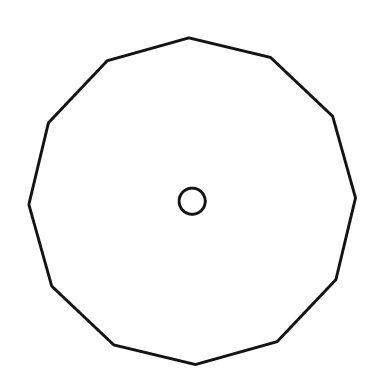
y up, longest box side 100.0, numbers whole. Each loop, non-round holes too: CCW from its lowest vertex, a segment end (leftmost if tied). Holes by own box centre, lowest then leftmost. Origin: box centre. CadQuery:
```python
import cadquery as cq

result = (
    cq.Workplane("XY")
    .moveTo(1.0, -50.0)
    .lineTo(26.0, -43.0)
    .lineTo(44.0, -24.0)
    .lineTo(50.0, 1.0)
    .lineTo(43.0, 26.0)
    .lineTo(24.0, 44.0)
    .lineTo(-1.0, 50.0)
    .lineTo(-26.0, 43.0)
    .lineTo(-44.0, 24.0)
    .lineTo(-50.0, -1.0)
    .lineTo(-43.0, -26.0)
    .lineTo(-24.0, -44.0)
    .close()
    .moveTo(0.0, 0.0)
    .circle(4.0)
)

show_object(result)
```